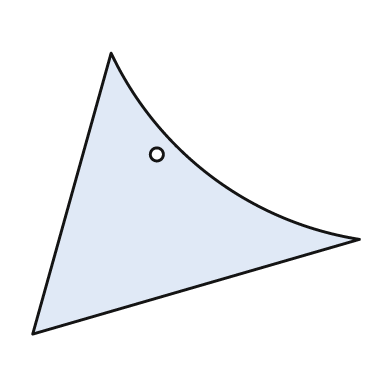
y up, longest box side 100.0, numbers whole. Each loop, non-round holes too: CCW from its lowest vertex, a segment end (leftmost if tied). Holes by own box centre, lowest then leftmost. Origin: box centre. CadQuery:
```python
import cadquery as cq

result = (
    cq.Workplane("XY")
    .moveTo(-50.0, -43.0)
    .lineTo(50.0, -14.0)
    .threePointArc((5.0, 5.0), (-26.0, 43.0))
    .close()
    .moveTo(-12.0, 12.0)
    .circle(2.0)
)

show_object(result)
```